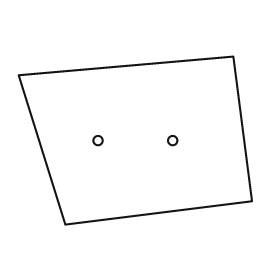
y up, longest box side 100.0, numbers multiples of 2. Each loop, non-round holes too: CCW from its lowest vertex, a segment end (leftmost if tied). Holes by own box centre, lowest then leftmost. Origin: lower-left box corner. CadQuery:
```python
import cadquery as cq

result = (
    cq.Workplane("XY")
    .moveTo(20.0, 0.0)
    .lineTo(100.0, 10.0)
    .lineTo(92.0, 72.0)
    .lineTo(0.0, 64.0)
    .close()
    .moveTo(34.0, 36.0)
    .circle(2.0)
    .moveTo(66.0, 36.0)
    .circle(2.0)
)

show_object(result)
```